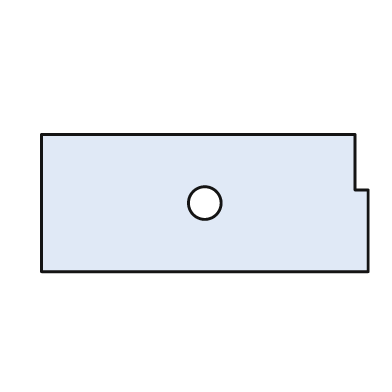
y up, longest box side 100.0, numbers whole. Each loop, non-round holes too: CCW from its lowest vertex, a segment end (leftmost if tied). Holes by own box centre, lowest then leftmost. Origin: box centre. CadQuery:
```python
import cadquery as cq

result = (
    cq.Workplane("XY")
    .moveTo(-50.0, -21.0)
    .lineTo(50.0, -21.0)
    .lineTo(50.0, 4.0)
    .lineTo(46.0, 4.0)
    .lineTo(46.0, 21.0)
    .lineTo(-50.0, 21.0)
    .close()
    .moveTo(0.0, 0.0)
    .circle(5.0)
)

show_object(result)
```